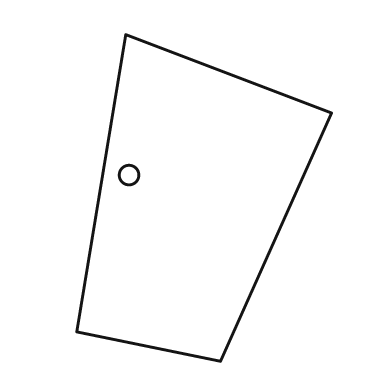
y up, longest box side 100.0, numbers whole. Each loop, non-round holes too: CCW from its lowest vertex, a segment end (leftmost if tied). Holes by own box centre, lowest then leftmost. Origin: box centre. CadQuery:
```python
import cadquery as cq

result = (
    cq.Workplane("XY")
    .moveTo(5.0, -50.0)
    .lineTo(39.0, 26.0)
    .lineTo(-24.0, 50.0)
    .lineTo(-39.0, -41.0)
    .close()
    .moveTo(-23.0, 7.0)
    .circle(3.0)
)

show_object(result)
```